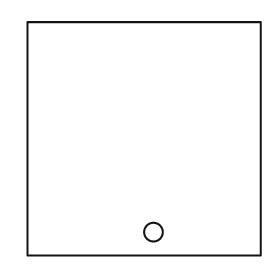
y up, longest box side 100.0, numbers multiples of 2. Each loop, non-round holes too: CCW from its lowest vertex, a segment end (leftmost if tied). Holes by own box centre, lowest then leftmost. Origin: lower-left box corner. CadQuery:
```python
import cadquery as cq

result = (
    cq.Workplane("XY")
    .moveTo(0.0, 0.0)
    .lineTo(100.0, 0.0)
    .lineTo(100.0, 100.0)
    .lineTo(0.0, 100.0)
    .close()
    .moveTo(54.0, 10.0)
    .circle(4.0)
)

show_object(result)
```